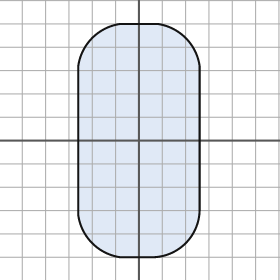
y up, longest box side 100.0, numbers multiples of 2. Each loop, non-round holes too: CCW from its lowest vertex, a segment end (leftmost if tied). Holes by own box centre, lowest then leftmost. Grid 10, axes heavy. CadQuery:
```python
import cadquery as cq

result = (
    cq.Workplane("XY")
    .moveTo(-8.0, -50.0)
    .lineTo(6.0, -50.0)
    .threePointArc((20.0, -44.0), (26.0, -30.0))
    .lineTo(26.0, 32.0)
    .threePointArc((20.0, 44.0), (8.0, 50.0))
    .lineTo(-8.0, 50.0)
    .threePointArc((-20.0, 44.0), (-26.0, 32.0))
    .lineTo(-26.0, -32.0)
    .threePointArc((-20.0, -44.0), (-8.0, -50.0))
    .close()
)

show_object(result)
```